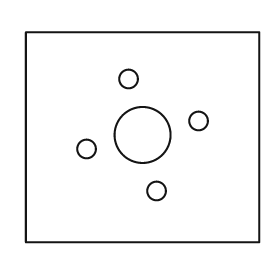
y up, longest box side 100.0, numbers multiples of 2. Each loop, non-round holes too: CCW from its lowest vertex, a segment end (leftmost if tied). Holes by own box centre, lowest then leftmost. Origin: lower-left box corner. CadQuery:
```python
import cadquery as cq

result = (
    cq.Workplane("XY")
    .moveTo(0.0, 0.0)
    .lineTo(100.0, 0.0)
    .lineTo(100.0, 90.0)
    .lineTo(0.0, 90.0)
    .close()
    .moveTo(56.0, 22.0)
    .circle(4.0)
    .moveTo(26.0, 40.0)
    .circle(4.0)
    .moveTo(50.0, 46.0)
    .circle(12.0)
    .moveTo(74.0, 52.0)
    .circle(4.0)
    .moveTo(44.0, 70.0)
    .circle(4.0)
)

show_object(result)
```